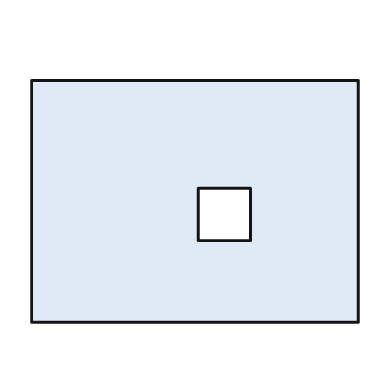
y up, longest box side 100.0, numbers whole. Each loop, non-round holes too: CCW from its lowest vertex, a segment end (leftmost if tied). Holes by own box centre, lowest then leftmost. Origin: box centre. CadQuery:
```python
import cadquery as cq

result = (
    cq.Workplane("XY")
    .moveTo(-50.0, -37.0)
    .lineTo(50.0, -37.0)
    .lineTo(50.0, 37.0)
    .lineTo(-50.0, 37.0)
    .close()
    .moveTo(1.0, -12.0)
    .lineTo(17.0, -12.0)
    .lineTo(17.0, 4.0)
    .lineTo(1.0, 4.0)
    .close()
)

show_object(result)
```